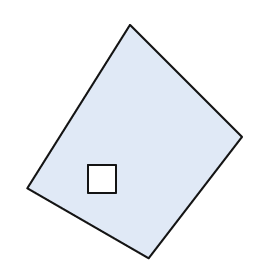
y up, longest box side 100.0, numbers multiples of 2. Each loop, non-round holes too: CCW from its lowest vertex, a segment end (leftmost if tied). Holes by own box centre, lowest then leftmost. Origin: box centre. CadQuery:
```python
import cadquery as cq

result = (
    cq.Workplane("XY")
    .moveTo(6.0, -50.0)
    .lineTo(46.0, 2.0)
    .lineTo(-2.0, 50.0)
    .lineTo(-46.0, -20.0)
    .close()
    .moveTo(-20.0, -22.0)
    .lineTo(-8.0, -22.0)
    .lineTo(-8.0, -10.0)
    .lineTo(-20.0, -10.0)
    .close()
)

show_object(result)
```